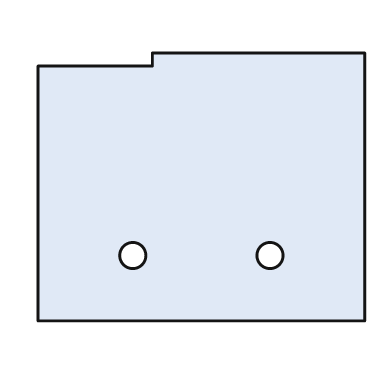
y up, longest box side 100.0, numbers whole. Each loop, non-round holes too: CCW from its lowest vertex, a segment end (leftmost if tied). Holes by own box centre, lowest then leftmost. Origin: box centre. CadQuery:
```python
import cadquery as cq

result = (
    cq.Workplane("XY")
    .moveTo(-50.0, -41.0)
    .lineTo(50.0, -41.0)
    .lineTo(50.0, 41.0)
    .lineTo(-15.0, 41.0)
    .lineTo(-15.0, 37.0)
    .lineTo(-50.0, 37.0)
    .close()
    .moveTo(-21.0, -21.0)
    .circle(4.0)
    .moveTo(21.0, -21.0)
    .circle(4.0)
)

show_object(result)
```